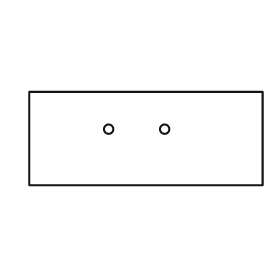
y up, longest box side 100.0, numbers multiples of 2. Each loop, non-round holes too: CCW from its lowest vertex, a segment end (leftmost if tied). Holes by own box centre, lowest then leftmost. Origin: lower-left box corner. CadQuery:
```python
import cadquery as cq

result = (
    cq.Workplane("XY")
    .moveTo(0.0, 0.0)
    .lineTo(100.0, 0.0)
    .lineTo(100.0, 40.0)
    .lineTo(0.0, 40.0)
    .close()
    .moveTo(34.0, 24.0)
    .circle(2.0)
    .moveTo(58.0, 24.0)
    .circle(2.0)
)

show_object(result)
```